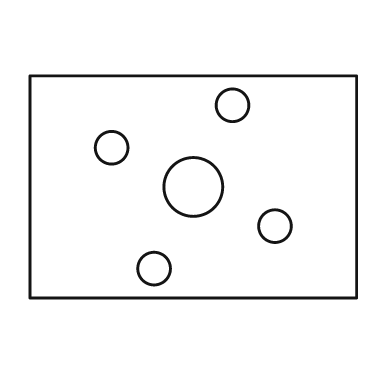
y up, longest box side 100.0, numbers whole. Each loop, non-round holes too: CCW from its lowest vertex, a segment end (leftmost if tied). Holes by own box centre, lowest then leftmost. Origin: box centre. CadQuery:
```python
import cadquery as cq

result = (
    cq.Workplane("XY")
    .moveTo(-50.0, -34.0)
    .lineTo(50.0, -34.0)
    .lineTo(50.0, 34.0)
    .lineTo(-50.0, 34.0)
    .close()
    .moveTo(-12.0, -25.0)
    .circle(5.0)
    .moveTo(25.0, -12.0)
    .circle(5.0)
    .moveTo(0.0, 0.0)
    .circle(9.0)
    .moveTo(-25.0, 12.0)
    .circle(5.0)
    .moveTo(12.0, 25.0)
    .circle(5.0)
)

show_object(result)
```